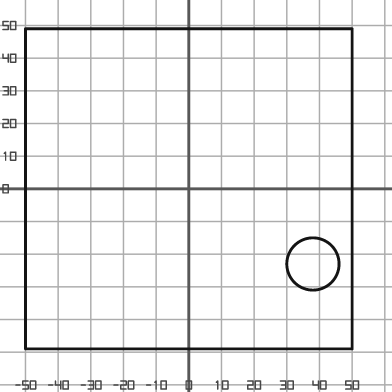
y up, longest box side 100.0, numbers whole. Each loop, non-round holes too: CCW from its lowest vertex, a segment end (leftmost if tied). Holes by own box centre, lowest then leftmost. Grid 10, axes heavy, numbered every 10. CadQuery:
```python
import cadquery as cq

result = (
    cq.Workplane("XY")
    .moveTo(-50.0, -49.0)
    .lineTo(50.0, -49.0)
    .lineTo(50.0, 49.0)
    .lineTo(-50.0, 49.0)
    .close()
    .moveTo(38.0, -23.0)
    .circle(8.0)
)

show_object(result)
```